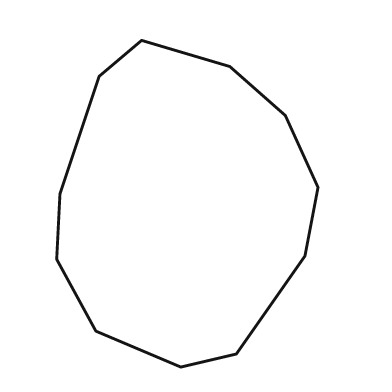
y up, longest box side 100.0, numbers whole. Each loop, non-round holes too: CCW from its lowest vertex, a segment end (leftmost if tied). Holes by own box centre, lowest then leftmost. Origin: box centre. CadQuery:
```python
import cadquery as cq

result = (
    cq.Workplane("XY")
    .moveTo(-2.0, -50.0)
    .lineTo(15.0, -46.0)
    .lineTo(36.0, -16.0)
    .lineTo(40.0, 5.0)
    .lineTo(30.0, 27.0)
    .lineTo(13.0, 42.0)
    .lineTo(-14.0, 50.0)
    .lineTo(-27.0, 39.0)
    .lineTo(-39.0, 3.0)
    .lineTo(-40.0, -17.0)
    .lineTo(-28.0, -39.0)
    .close()
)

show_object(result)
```